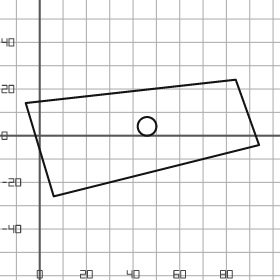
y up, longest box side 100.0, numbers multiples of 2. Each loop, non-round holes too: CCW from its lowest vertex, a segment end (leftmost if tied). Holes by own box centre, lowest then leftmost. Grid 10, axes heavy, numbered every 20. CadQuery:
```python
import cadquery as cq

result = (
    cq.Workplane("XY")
    .moveTo(6.0, -26.0)
    .lineTo(94.0, -4.0)
    .lineTo(84.0, 24.0)
    .lineTo(-6.0, 14.0)
    .close()
    .moveTo(46.0, 4.0)
    .circle(4.0)
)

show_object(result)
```